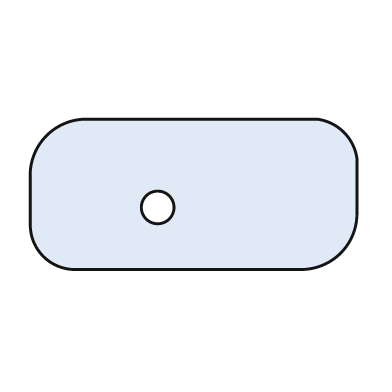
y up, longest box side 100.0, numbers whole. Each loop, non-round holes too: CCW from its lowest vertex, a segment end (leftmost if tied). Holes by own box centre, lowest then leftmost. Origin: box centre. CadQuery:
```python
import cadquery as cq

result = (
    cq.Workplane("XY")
    .moveTo(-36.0, -23.0)
    .lineTo(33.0, -23.0)
    .threePointArc((45.0, -18.0), (50.0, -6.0))
    .lineTo(50.0, 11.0)
    .threePointArc((46.0, 19.0), (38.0, 23.0))
    .lineTo(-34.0, 23.0)
    .threePointArc((-45.0, 18.0), (-50.0, 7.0))
    .lineTo(-50.0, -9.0)
    .threePointArc((-46.0, -19.0), (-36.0, -23.0))
    .close()
    .moveTo(-11.0, -4.0)
    .circle(5.0)
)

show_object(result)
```